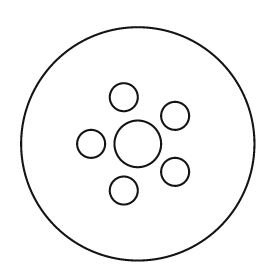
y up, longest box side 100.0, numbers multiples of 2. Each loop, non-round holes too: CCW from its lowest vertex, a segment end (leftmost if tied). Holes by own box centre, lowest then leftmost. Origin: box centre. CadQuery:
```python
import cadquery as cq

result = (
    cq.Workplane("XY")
    .moveTo(0.0, 0.0)
    .circle(50.0)
    .moveTo(-6.0, -20.0)
    .circle(6.0)
    .moveTo(16.0, -12.0)
    .circle(6.0)
    .moveTo(-20.0, 0.0)
    .circle(6.0)
    .moveTo(0.0, 0.0)
    .circle(10.0)
    .moveTo(16.0, 12.0)
    .circle(6.0)
    .moveTo(-6.0, 20.0)
    .circle(6.0)
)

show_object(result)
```